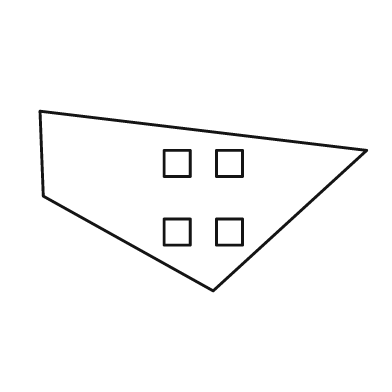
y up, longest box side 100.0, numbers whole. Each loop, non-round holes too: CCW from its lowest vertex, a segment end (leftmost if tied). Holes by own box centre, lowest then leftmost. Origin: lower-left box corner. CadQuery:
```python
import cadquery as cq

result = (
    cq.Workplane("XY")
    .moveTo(53.0, 0.0)
    .lineTo(100.0, 43.0)
    .lineTo(0.0, 55.0)
    .lineTo(1.0, 29.0)
    .close()
    .moveTo(38.0, 14.0)
    .lineTo(46.0, 14.0)
    .lineTo(46.0, 22.0)
    .lineTo(38.0, 22.0)
    .close()
    .moveTo(54.0, 14.0)
    .lineTo(62.0, 14.0)
    .lineTo(62.0, 22.0)
    .lineTo(54.0, 22.0)
    .close()
    .moveTo(38.0, 35.0)
    .lineTo(46.0, 35.0)
    .lineTo(46.0, 43.0)
    .lineTo(38.0, 43.0)
    .close()
    .moveTo(54.0, 35.0)
    .lineTo(62.0, 35.0)
    .lineTo(62.0, 43.0)
    .lineTo(54.0, 43.0)
    .close()
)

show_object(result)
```